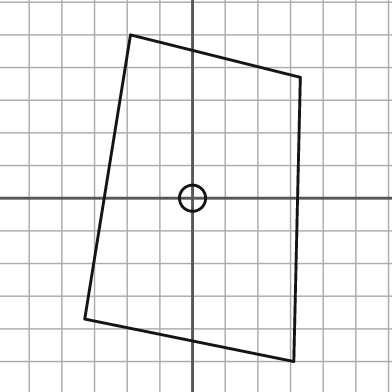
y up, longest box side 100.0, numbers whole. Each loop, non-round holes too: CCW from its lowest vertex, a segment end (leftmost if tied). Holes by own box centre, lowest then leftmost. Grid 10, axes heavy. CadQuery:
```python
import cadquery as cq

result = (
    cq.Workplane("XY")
    .moveTo(31.0, -50.0)
    .lineTo(33.0, 37.0)
    .lineTo(-19.0, 50.0)
    .lineTo(-33.0, -37.0)
    .close()
    .moveTo(0.0, 0.0)
    .circle(4.0)
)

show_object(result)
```